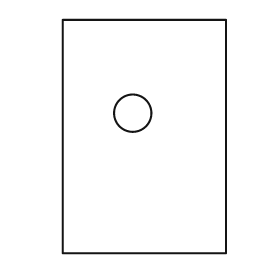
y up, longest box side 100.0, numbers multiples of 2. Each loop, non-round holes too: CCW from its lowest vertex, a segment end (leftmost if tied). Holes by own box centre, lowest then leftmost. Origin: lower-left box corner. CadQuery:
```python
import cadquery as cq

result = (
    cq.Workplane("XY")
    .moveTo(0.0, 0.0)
    .lineTo(70.0, 0.0)
    .lineTo(70.0, 100.0)
    .lineTo(0.0, 100.0)
    .close()
    .moveTo(30.0, 60.0)
    .circle(8.0)
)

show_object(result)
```